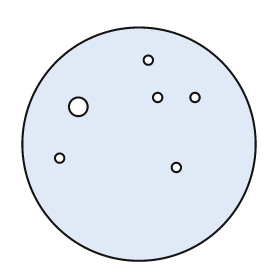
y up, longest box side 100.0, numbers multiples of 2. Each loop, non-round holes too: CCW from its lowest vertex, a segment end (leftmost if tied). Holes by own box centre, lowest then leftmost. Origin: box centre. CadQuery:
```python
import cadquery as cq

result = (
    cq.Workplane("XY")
    .moveTo(0.0, 0.0)
    .circle(50.0)
    .moveTo(16.0, -10.0)
    .circle(2.0)
    .moveTo(-34.0, -6.0)
    .circle(2.0)
    .moveTo(-26.0, 16.0)
    .circle(4.0)
    .moveTo(8.0, 20.0)
    .circle(2.0)
    .moveTo(24.0, 20.0)
    .circle(2.0)
    .moveTo(4.0, 36.0)
    .circle(2.0)
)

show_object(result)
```